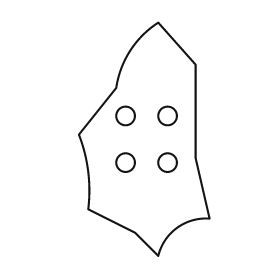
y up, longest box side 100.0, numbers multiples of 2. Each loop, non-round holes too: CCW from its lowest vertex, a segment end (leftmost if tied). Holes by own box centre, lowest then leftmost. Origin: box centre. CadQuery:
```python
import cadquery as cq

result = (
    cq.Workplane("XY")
    .moveTo(6.0, -50.0)
    .threePointArc((14.0, -38.0), (28.0, -34.0))
    .lineTo(22.0, -8.0)
    .lineTo(22.0, 32.0)
    .lineTo(6.0, 50.0)
    .threePointArc((-6.0, 38.0), (-12.0, 22.0))
    .lineTo(-28.0, 2.0)
    .threePointArc((-24.0, -14.0), (-24.0, -30.0))
    .lineTo(-4.0, -40.0)
    .close()
    .moveTo(-8.0, -10.0)
    .circle(4.0)
    .moveTo(10.0, -10.0)
    .circle(4.0)
    .moveTo(-8.0, 10.0)
    .circle(4.0)
    .moveTo(10.0, 10.0)
    .circle(4.0)
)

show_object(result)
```